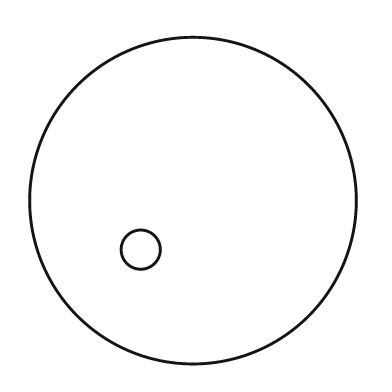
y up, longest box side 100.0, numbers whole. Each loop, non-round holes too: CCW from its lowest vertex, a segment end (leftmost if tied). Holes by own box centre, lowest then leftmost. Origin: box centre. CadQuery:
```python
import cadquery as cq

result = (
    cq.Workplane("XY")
    .moveTo(0.0, 0.0)
    .circle(50.0)
    .moveTo(-16.0, -15.0)
    .circle(6.0)
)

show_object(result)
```